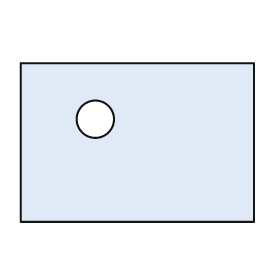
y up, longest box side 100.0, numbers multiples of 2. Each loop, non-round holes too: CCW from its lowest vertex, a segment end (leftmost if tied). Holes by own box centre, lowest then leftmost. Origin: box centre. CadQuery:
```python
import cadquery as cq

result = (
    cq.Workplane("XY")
    .moveTo(-50.0, -34.0)
    .lineTo(50.0, -34.0)
    .lineTo(50.0, 34.0)
    .lineTo(-50.0, 34.0)
    .close()
    .moveTo(-18.0, 10.0)
    .circle(8.0)
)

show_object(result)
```